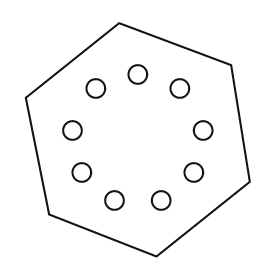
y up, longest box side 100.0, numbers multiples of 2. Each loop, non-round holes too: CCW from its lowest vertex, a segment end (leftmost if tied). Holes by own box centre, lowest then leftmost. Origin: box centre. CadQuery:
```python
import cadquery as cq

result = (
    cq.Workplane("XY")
    .moveTo(8.0, -50.0)
    .lineTo(48.0, -18.0)
    .lineTo(40.0, 32.0)
    .lineTo(-8.0, 50.0)
    .lineTo(-48.0, 18.0)
    .lineTo(-38.0, -32.0)
    .close()
    .moveTo(-10.0, -26.0)
    .circle(4.0)
    .moveTo(10.0, -26.0)
    .circle(4.0)
    .moveTo(-24.0, -14.0)
    .circle(4.0)
    .moveTo(24.0, -14.0)
    .circle(4.0)
    .moveTo(-28.0, 4.0)
    .circle(4.0)
    .moveTo(28.0, 4.0)
    .circle(4.0)
    .moveTo(-18.0, 22.0)
    .circle(4.0)
    .moveTo(18.0, 22.0)
    .circle(4.0)
    .moveTo(0.0, 28.0)
    .circle(4.0)
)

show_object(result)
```